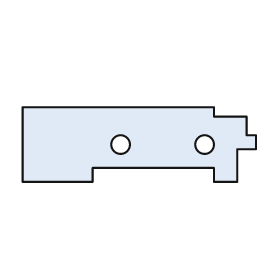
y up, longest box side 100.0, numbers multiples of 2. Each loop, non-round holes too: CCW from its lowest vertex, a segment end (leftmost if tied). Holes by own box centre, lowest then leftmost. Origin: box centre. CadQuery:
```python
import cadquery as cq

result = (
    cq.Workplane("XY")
    .moveTo(-50.0, -16.0)
    .lineTo(-20.0, -16.0)
    .lineTo(-20.0, -10.0)
    .lineTo(32.0, -10.0)
    .lineTo(32.0, -16.0)
    .lineTo(42.0, -16.0)
    .lineTo(42.0, -2.0)
    .lineTo(50.0, -2.0)
    .lineTo(50.0, 4.0)
    .lineTo(46.0, 4.0)
    .lineTo(46.0, 12.0)
    .lineTo(32.0, 12.0)
    .lineTo(32.0, 16.0)
    .lineTo(-50.0, 16.0)
    .close()
    .moveTo(-8.0, 0.0)
    .circle(4.0)
    .moveTo(28.0, 0.0)
    .circle(4.0)
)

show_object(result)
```